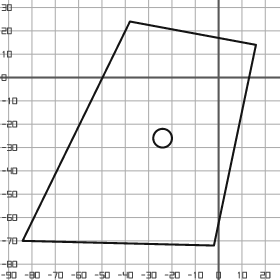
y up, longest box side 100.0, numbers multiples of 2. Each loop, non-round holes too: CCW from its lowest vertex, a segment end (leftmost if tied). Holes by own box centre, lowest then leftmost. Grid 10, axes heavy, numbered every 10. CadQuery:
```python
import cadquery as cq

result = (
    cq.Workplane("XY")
    .moveTo(-2.0, -72.0)
    .lineTo(16.0, 14.0)
    .lineTo(-38.0, 24.0)
    .lineTo(-84.0, -70.0)
    .close()
    .moveTo(-24.0, -26.0)
    .circle(4.0)
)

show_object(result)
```